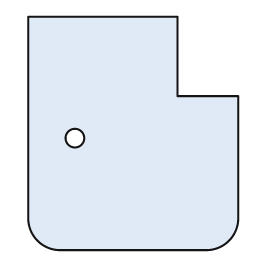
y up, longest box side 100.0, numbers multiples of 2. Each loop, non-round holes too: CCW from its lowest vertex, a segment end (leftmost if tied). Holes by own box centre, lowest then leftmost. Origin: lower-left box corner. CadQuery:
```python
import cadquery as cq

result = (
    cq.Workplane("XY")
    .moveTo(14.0, 0.0)
    .lineTo(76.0, 0.0)
    .threePointArc((86.0, 4.0), (90.0, 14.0))
    .lineTo(90.0, 66.0)
    .lineTo(64.0, 66.0)
    .lineTo(64.0, 100.0)
    .lineTo(0.0, 100.0)
    .lineTo(0.0, 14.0)
    .threePointArc((4.0, 4.0), (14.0, 0.0))
    .close()
    .moveTo(20.0, 48.0)
    .circle(4.0)
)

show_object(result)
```